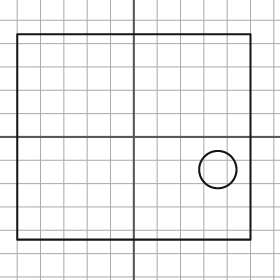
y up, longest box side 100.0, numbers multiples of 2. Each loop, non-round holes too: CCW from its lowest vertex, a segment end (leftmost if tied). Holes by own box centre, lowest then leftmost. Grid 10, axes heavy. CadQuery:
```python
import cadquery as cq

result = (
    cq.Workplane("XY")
    .moveTo(-50.0, -44.0)
    .lineTo(50.0, -44.0)
    .lineTo(50.0, 44.0)
    .lineTo(-50.0, 44.0)
    .close()
    .moveTo(36.0, -14.0)
    .circle(8.0)
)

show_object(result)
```